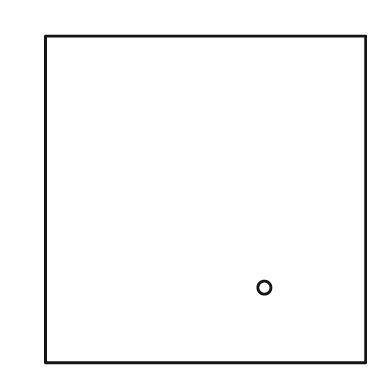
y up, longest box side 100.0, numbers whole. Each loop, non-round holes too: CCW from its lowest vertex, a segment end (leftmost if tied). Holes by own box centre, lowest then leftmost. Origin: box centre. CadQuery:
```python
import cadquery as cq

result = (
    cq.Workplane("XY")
    .moveTo(-49.0, -50.0)
    .lineTo(49.0, -50.0)
    .lineTo(49.0, 50.0)
    .lineTo(-49.0, 50.0)
    .close()
    .moveTo(18.0, -27.0)
    .circle(2.0)
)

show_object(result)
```